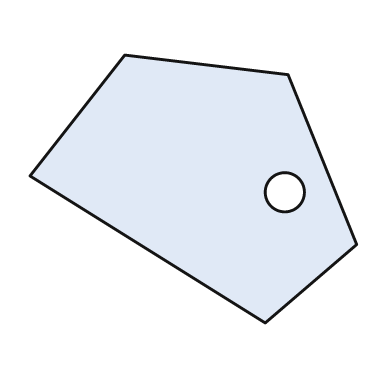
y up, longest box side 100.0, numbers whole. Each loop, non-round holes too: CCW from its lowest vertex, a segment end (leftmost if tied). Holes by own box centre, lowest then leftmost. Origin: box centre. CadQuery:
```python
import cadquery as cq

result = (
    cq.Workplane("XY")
    .moveTo(22.0, -41.0)
    .lineTo(50.0, -17.0)
    .lineTo(29.0, 35.0)
    .lineTo(-21.0, 41.0)
    .lineTo(-50.0, 4.0)
    .close()
    .moveTo(28.0, -1.0)
    .circle(6.0)
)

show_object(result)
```